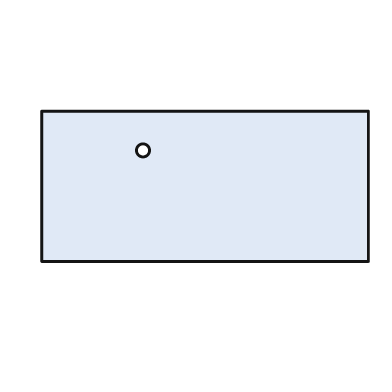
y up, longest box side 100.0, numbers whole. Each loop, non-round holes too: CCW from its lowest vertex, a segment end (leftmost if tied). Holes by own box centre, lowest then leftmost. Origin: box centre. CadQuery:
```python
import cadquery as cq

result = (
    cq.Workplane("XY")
    .moveTo(-50.0, -23.0)
    .lineTo(50.0, -23.0)
    .lineTo(50.0, 23.0)
    .lineTo(-50.0, 23.0)
    .close()
    .moveTo(-19.0, 11.0)
    .circle(2.0)
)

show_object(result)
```